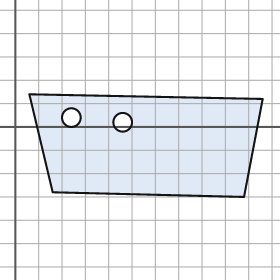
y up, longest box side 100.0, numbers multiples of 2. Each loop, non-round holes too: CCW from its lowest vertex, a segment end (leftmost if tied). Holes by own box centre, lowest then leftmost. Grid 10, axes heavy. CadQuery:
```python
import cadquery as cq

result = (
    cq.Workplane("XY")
    .moveTo(98.0, -30.0)
    .lineTo(106.0, 12.0)
    .lineTo(6.0, 14.0)
    .lineTo(16.0, -28.0)
    .close()
    .moveTo(46.0, 2.0)
    .circle(4.0)
    .moveTo(24.0, 4.0)
    .circle(4.0)
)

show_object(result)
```